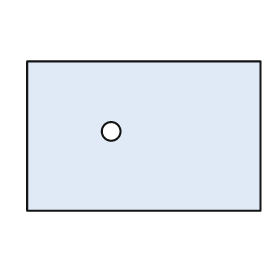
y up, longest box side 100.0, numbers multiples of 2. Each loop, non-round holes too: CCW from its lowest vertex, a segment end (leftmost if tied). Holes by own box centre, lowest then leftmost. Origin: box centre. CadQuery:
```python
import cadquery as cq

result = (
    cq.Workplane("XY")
    .moveTo(-50.0, -32.0)
    .lineTo(50.0, -32.0)
    .lineTo(50.0, 32.0)
    .lineTo(-50.0, 32.0)
    .close()
    .moveTo(-14.0, 2.0)
    .circle(4.0)
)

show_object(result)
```